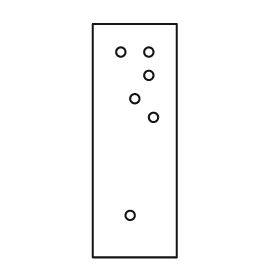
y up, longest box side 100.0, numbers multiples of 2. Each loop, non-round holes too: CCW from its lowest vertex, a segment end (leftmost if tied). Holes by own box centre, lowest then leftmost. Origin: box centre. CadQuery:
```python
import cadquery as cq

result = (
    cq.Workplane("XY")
    .moveTo(-18.0, -50.0)
    .lineTo(18.0, -50.0)
    .lineTo(18.0, 50.0)
    .lineTo(-18.0, 50.0)
    .close()
    .moveTo(-2.0, -32.0)
    .circle(2.0)
    .moveTo(8.0, 10.0)
    .circle(2.0)
    .moveTo(0.0, 18.0)
    .circle(2.0)
    .moveTo(6.0, 28.0)
    .circle(2.0)
    .moveTo(-6.0, 38.0)
    .circle(2.0)
    .moveTo(6.0, 38.0)
    .circle(2.0)
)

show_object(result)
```